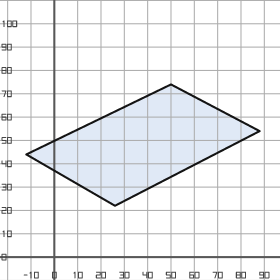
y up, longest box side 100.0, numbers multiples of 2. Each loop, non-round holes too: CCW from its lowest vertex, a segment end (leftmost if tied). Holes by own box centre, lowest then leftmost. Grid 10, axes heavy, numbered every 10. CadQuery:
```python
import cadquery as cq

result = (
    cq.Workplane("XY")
    .moveTo(26.0, 22.0)
    .lineTo(88.0, 54.0)
    .lineTo(50.0, 74.0)
    .lineTo(-12.0, 44.0)
    .close()
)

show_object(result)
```